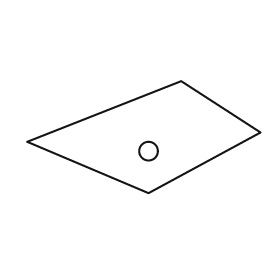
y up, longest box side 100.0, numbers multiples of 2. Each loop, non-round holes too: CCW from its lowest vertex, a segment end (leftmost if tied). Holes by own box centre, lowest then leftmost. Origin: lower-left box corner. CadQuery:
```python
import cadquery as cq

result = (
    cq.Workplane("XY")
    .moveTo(52.0, 0.0)
    .lineTo(100.0, 26.0)
    .lineTo(66.0, 48.0)
    .lineTo(0.0, 22.0)
    .close()
    .moveTo(52.0, 18.0)
    .circle(4.0)
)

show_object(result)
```